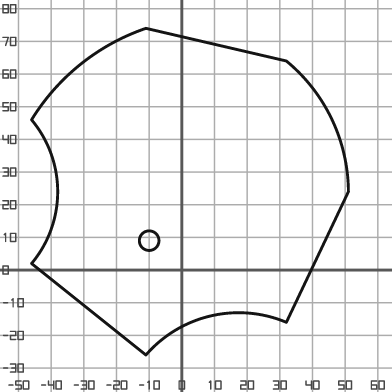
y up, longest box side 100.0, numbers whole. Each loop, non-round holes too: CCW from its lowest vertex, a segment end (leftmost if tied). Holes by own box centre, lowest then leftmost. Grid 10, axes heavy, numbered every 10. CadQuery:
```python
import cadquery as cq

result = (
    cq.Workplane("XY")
    .moveTo(-11.0, -26.0)
    .threePointArc((9.0, -14.0), (32.0, -16.0))
    .lineTo(51.0, 24.0)
    .threePointArc((46.0, 46.0), (32.0, 64.0))
    .lineTo(-11.0, 74.0)
    .threePointArc((-31.0, 63.0), (-46.0, 46.0))
    .threePointArc((-38.0, 24.0), (-46.0, 2.0))
    .close()
    .moveTo(-10.0, 9.0)
    .circle(3.0)
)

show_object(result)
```